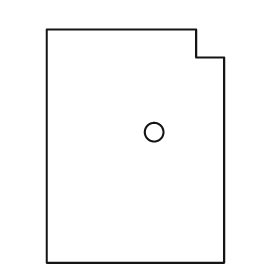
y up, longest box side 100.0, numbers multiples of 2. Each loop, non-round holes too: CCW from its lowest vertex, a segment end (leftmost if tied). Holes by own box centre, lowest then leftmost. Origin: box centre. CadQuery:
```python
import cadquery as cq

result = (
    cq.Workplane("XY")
    .moveTo(-38.0, -50.0)
    .lineTo(38.0, -50.0)
    .lineTo(38.0, 38.0)
    .lineTo(26.0, 38.0)
    .lineTo(26.0, 50.0)
    .lineTo(-38.0, 50.0)
    .close()
    .moveTo(8.0, 6.0)
    .circle(4.0)
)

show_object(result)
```